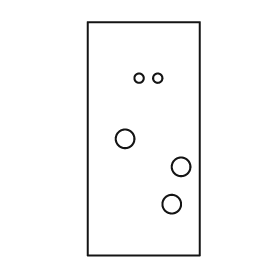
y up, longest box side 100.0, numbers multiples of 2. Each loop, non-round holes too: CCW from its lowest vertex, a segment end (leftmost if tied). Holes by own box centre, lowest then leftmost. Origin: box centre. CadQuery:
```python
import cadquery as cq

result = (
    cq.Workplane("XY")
    .moveTo(-24.0, -50.0)
    .lineTo(24.0, -50.0)
    .lineTo(24.0, 50.0)
    .lineTo(-24.0, 50.0)
    .close()
    .moveTo(12.0, -28.0)
    .circle(4.0)
    .moveTo(16.0, -12.0)
    .circle(4.0)
    .moveTo(-8.0, 0.0)
    .circle(4.0)
    .moveTo(-2.0, 26.0)
    .circle(2.0)
    .moveTo(6.0, 26.0)
    .circle(2.0)
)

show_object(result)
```